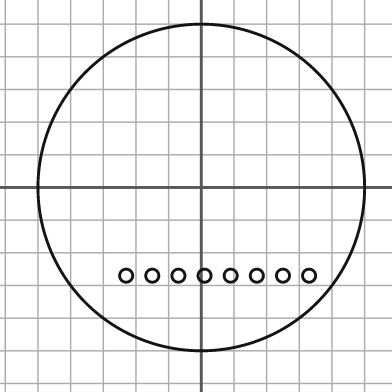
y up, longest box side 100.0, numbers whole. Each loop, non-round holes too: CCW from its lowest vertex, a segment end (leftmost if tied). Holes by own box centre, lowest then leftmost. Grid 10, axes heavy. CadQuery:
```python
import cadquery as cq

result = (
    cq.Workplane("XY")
    .moveTo(0.0, 0.0)
    .circle(50.0)
    .moveTo(-23.0, -27.0)
    .circle(2.0)
    .moveTo(-15.0, -27.0)
    .circle(2.0)
    .moveTo(-7.0, -27.0)
    .circle(2.0)
    .moveTo(1.0, -27.0)
    .circle(2.0)
    .moveTo(9.0, -27.0)
    .circle(2.0)
    .moveTo(17.0, -27.0)
    .circle(2.0)
    .moveTo(25.0, -27.0)
    .circle(2.0)
    .moveTo(33.0, -27.0)
    .circle(2.0)
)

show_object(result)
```